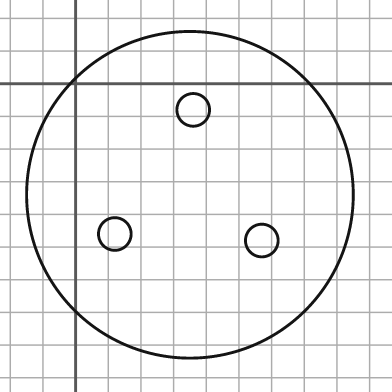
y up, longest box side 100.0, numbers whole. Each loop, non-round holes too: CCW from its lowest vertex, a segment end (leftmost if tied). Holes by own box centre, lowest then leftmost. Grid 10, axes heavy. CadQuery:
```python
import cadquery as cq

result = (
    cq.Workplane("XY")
    .moveTo(35.0, -34.0)
    .circle(50.0)
    .moveTo(57.0, -48.0)
    .circle(5.0)
    .moveTo(12.0, -46.0)
    .circle(5.0)
    .moveTo(36.0, -8.0)
    .circle(5.0)
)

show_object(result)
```